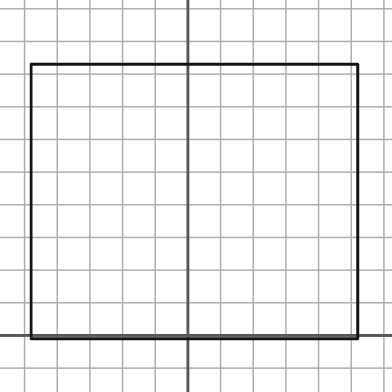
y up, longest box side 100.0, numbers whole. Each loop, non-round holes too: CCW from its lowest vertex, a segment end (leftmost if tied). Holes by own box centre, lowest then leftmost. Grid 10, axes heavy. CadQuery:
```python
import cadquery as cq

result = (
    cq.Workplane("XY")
    .moveTo(-48.0, -1.0)
    .lineTo(52.0, -1.0)
    .lineTo(52.0, 83.0)
    .lineTo(-48.0, 83.0)
    .close()
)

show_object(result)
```